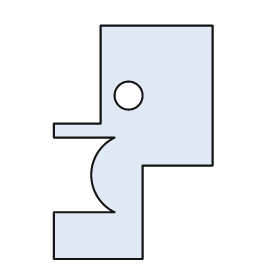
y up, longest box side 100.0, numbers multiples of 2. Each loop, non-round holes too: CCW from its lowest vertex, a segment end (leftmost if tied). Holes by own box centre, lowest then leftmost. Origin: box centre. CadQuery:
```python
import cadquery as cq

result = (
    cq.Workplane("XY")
    .moveTo(-34.0, -50.0)
    .lineTo(4.0, -50.0)
    .lineTo(4.0, -10.0)
    .lineTo(34.0, -10.0)
    .lineTo(34.0, 50.0)
    .lineTo(-14.0, 50.0)
    .lineTo(-14.0, 8.0)
    .lineTo(-34.0, 8.0)
    .lineTo(-34.0, 2.0)
    .lineTo(-8.0, 2.0)
    .threePointArc((-18.0, -14.0), (-8.0, -30.0))
    .lineTo(-34.0, -30.0)
    .close()
    .moveTo(-2.0, 20.0)
    .circle(6.0)
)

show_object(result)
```